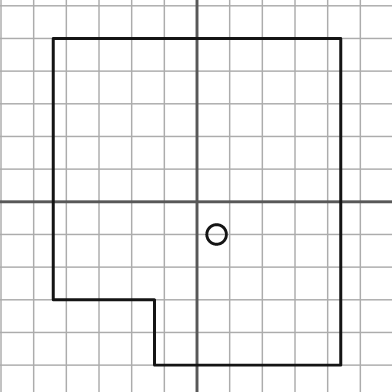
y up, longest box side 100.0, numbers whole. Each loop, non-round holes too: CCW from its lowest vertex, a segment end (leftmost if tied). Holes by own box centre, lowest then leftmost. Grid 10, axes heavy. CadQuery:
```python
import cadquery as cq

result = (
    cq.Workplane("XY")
    .moveTo(-13.0, -50.0)
    .lineTo(44.0, -50.0)
    .lineTo(44.0, 50.0)
    .lineTo(-44.0, 50.0)
    .lineTo(-44.0, -30.0)
    .lineTo(-13.0, -30.0)
    .close()
    .moveTo(6.0, -10.0)
    .circle(3.0)
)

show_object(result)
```